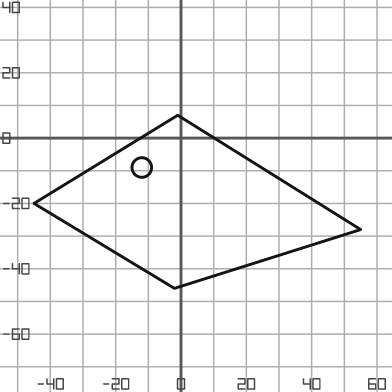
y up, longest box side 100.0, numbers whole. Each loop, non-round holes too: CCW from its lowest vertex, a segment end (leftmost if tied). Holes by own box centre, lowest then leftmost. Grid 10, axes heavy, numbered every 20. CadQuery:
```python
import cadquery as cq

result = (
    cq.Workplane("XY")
    .moveTo(-2.0, -46.0)
    .lineTo(55.0, -28.0)
    .lineTo(-1.0, 7.0)
    .lineTo(-45.0, -20.0)
    .close()
    .moveTo(-12.0, -9.0)
    .circle(3.0)
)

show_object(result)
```